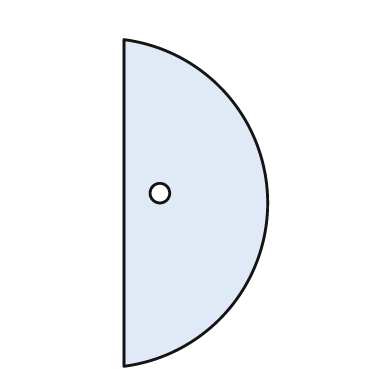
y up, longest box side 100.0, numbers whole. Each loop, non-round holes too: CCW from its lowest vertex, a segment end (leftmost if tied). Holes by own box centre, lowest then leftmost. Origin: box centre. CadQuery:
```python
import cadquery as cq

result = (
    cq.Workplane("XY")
    .moveTo(-22.0, -50.0)
    .threePointArc((22.0, 0.0), (-22.0, 50.0))
    .close()
    .moveTo(-11.0, 3.0)
    .circle(3.0)
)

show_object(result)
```